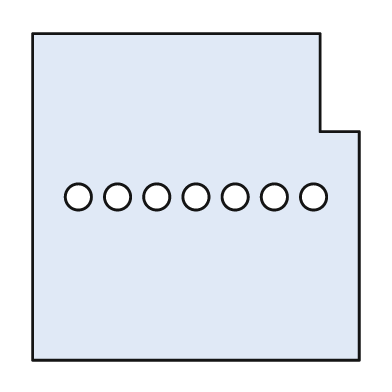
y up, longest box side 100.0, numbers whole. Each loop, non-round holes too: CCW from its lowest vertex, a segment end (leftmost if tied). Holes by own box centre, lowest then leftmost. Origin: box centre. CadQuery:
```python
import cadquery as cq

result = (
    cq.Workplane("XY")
    .moveTo(-50.0, -50.0)
    .lineTo(50.0, -50.0)
    .lineTo(50.0, 20.0)
    .lineTo(38.0, 20.0)
    .lineTo(38.0, 50.0)
    .lineTo(-50.0, 50.0)
    .close()
    .moveTo(-36.0, 0.0)
    .circle(4.0)
    .moveTo(-24.0, 0.0)
    .circle(4.0)
    .moveTo(-12.0, 0.0)
    .circle(4.0)
    .moveTo(0.0, 0.0)
    .circle(4.0)
    .moveTo(12.0, 0.0)
    .circle(4.0)
    .moveTo(24.0, 0.0)
    .circle(4.0)
    .moveTo(36.0, 0.0)
    .circle(4.0)
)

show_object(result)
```